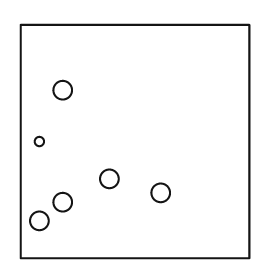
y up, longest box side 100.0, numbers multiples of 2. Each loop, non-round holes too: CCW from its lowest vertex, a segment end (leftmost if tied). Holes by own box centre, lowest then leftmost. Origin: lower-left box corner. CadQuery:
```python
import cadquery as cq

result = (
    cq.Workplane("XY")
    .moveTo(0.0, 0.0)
    .lineTo(98.0, 0.0)
    .lineTo(98.0, 100.0)
    .lineTo(0.0, 100.0)
    .close()
    .moveTo(8.0, 16.0)
    .circle(4.0)
    .moveTo(18.0, 24.0)
    .circle(4.0)
    .moveTo(60.0, 28.0)
    .circle(4.0)
    .moveTo(38.0, 34.0)
    .circle(4.0)
    .moveTo(8.0, 50.0)
    .circle(2.0)
    .moveTo(18.0, 72.0)
    .circle(4.0)
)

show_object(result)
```